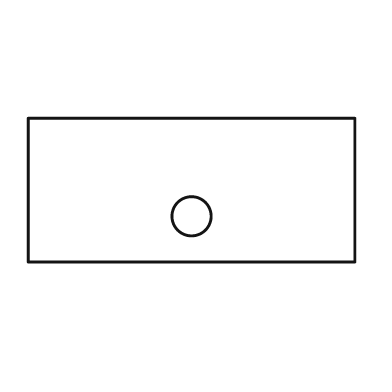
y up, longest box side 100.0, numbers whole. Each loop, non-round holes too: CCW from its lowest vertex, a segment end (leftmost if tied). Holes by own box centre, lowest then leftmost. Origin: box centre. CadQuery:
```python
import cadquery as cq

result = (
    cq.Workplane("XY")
    .moveTo(-50.0, -22.0)
    .lineTo(50.0, -22.0)
    .lineTo(50.0, 22.0)
    .lineTo(-50.0, 22.0)
    .close()
    .moveTo(0.0, -8.0)
    .circle(6.0)
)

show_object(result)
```